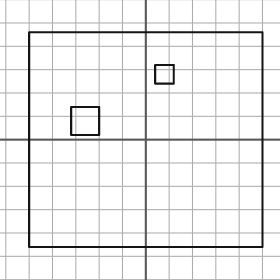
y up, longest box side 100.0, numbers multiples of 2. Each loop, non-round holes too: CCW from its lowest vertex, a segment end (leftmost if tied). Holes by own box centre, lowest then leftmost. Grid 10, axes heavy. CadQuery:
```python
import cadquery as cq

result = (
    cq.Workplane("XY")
    .moveTo(-50.0, -46.0)
    .lineTo(50.0, -46.0)
    .lineTo(50.0, 46.0)
    .lineTo(-50.0, 46.0)
    .close()
    .moveTo(-32.0, 2.0)
    .lineTo(-20.0, 2.0)
    .lineTo(-20.0, 14.0)
    .lineTo(-32.0, 14.0)
    .close()
    .moveTo(4.0, 24.0)
    .lineTo(12.0, 24.0)
    .lineTo(12.0, 32.0)
    .lineTo(4.0, 32.0)
    .close()
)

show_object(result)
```